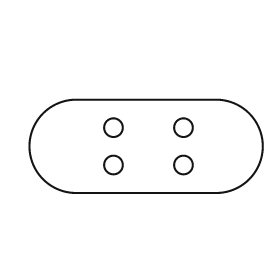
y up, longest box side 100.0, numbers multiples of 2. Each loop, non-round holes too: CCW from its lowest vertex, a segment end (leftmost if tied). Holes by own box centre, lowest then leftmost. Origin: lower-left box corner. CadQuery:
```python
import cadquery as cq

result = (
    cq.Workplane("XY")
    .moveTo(20.0, 0.0)
    .lineTo(80.0, 0.0)
    .threePointArc((100.0, 20.0), (80.0, 40.0))
    .lineTo(20.0, 40.0)
    .threePointArc((0.0, 20.0), (20.0, 0.0))
    .close()
    .moveTo(36.0, 12.0)
    .circle(4.0)
    .moveTo(66.0, 12.0)
    .circle(4.0)
    .moveTo(36.0, 28.0)
    .circle(4.0)
    .moveTo(66.0, 28.0)
    .circle(4.0)
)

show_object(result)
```